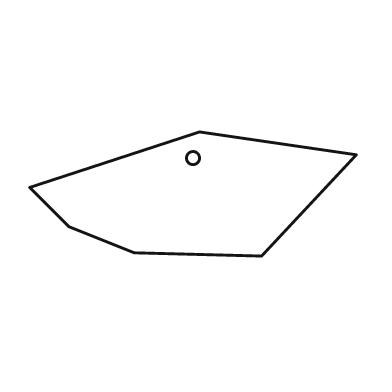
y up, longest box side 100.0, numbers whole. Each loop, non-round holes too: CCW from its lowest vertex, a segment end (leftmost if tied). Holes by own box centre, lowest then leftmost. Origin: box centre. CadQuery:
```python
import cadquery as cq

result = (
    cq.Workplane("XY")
    .moveTo(21.0, -19.0)
    .lineTo(50.0, 12.0)
    .lineTo(2.0, 19.0)
    .lineTo(-50.0, 2.0)
    .lineTo(-38.0, -10.0)
    .lineTo(-18.0, -18.0)
    .close()
    .moveTo(0.0, 11.0)
    .circle(2.0)
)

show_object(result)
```